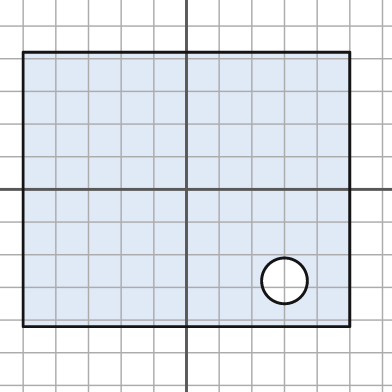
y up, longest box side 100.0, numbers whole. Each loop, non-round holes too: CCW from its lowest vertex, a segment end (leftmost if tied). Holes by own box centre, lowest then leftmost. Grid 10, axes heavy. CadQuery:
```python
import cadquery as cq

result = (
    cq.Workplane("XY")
    .moveTo(-50.0, -42.0)
    .lineTo(50.0, -42.0)
    .lineTo(50.0, 42.0)
    .lineTo(-50.0, 42.0)
    .close()
    .moveTo(30.0, -28.0)
    .circle(7.0)
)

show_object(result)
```